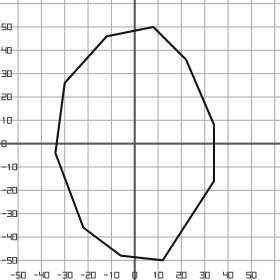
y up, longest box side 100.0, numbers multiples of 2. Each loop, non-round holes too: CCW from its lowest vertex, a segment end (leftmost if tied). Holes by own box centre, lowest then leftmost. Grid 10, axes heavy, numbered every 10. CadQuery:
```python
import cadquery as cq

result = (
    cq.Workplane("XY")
    .moveTo(12.0, -50.0)
    .lineTo(34.0, -16.0)
    .lineTo(34.0, 8.0)
    .lineTo(22.0, 36.0)
    .lineTo(8.0, 50.0)
    .lineTo(-12.0, 46.0)
    .lineTo(-30.0, 26.0)
    .lineTo(-34.0, -4.0)
    .lineTo(-22.0, -36.0)
    .lineTo(-6.0, -48.0)
    .close()
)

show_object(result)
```